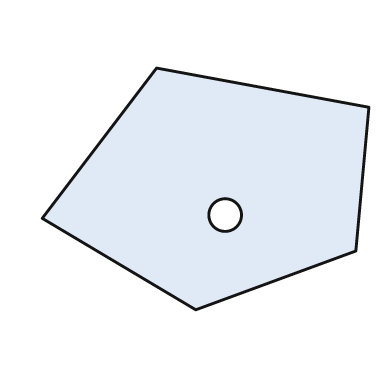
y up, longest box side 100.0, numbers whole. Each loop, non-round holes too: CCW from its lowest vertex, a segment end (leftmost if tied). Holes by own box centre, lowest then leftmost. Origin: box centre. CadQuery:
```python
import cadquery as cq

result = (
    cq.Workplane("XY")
    .moveTo(-3.0, -37.0)
    .lineTo(46.0, -19.0)
    .lineTo(50.0, 25.0)
    .lineTo(-15.0, 37.0)
    .lineTo(-50.0, -9.0)
    .close()
    .moveTo(6.0, -8.0)
    .circle(5.0)
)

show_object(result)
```